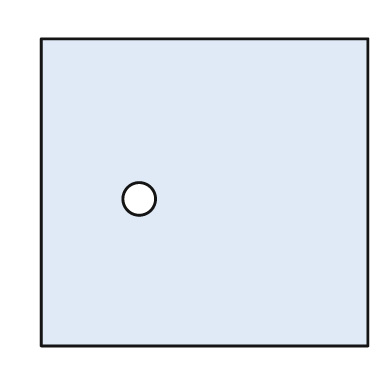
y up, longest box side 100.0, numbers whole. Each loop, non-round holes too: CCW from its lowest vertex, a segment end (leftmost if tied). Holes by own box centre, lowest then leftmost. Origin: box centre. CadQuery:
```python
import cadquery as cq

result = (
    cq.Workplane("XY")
    .moveTo(-50.0, -47.0)
    .lineTo(50.0, -47.0)
    .lineTo(50.0, 47.0)
    .lineTo(-50.0, 47.0)
    .close()
    .moveTo(-20.0, -2.0)
    .circle(5.0)
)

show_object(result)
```